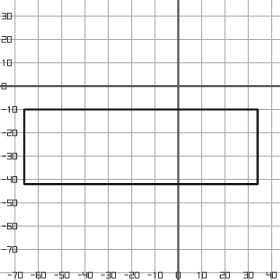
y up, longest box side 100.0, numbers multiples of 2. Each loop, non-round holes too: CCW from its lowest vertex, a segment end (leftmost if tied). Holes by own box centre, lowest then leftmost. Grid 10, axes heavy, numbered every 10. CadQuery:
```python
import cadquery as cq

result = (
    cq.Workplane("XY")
    .moveTo(-66.0, -42.0)
    .lineTo(34.0, -42.0)
    .lineTo(34.0, -10.0)
    .lineTo(-66.0, -10.0)
    .close()
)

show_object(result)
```